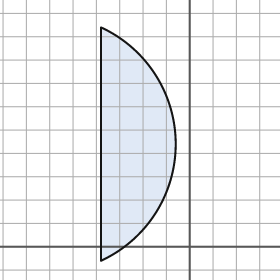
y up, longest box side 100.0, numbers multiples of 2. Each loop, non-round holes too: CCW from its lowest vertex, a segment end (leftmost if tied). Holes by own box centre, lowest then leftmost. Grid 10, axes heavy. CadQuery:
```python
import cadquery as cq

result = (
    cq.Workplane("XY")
    .moveTo(-38.0, -6.0)
    .threePointArc((-6.0, 44.0), (-38.0, 94.0))
    .close()
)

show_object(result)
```